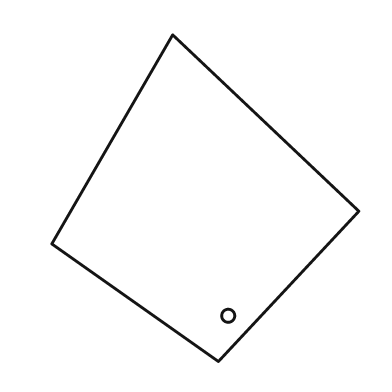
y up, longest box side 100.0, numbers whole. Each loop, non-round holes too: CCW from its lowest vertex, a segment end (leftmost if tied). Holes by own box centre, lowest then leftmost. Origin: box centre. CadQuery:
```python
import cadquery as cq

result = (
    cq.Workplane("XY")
    .moveTo(4.0, -50.0)
    .lineTo(47.0, -4.0)
    .lineTo(-10.0, 50.0)
    .lineTo(-47.0, -14.0)
    .close()
    .moveTo(7.0, -36.0)
    .circle(2.0)
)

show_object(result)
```